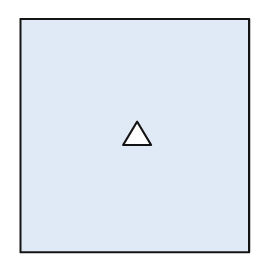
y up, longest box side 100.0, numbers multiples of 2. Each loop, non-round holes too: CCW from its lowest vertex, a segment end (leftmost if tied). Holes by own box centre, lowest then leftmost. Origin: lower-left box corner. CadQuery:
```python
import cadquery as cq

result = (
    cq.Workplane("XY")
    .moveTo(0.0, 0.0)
    .lineTo(98.0, 0.0)
    .lineTo(98.0, 100.0)
    .lineTo(0.0, 100.0)
    .close()
    .moveTo(44.0, 46.0)
    .lineTo(56.0, 46.0)
    .lineTo(50.0, 56.0)
    .close()
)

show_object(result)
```